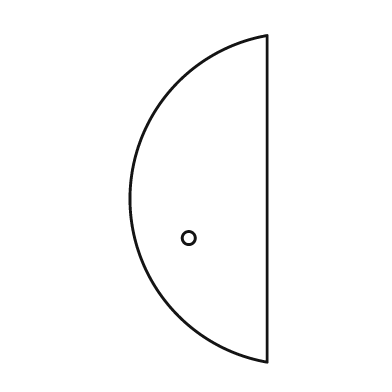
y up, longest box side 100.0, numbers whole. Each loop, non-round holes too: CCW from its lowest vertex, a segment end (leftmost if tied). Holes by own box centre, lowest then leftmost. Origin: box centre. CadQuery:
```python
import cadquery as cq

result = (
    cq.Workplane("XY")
    .moveTo(21.0, -50.0)
    .lineTo(21.0, 50.0)
    .threePointArc((-21.0, 0.0), (21.0, -50.0))
    .close()
    .moveTo(-3.0, -12.0)
    .circle(2.0)
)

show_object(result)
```